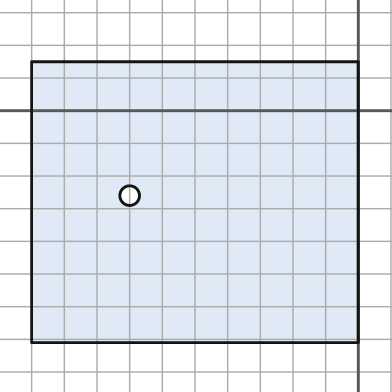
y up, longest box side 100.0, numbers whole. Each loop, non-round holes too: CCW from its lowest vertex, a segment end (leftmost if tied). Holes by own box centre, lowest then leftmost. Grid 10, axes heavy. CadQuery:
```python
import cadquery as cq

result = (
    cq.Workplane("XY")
    .moveTo(-100.0, -71.0)
    .lineTo(0.0, -71.0)
    .lineTo(0.0, 15.0)
    .lineTo(-100.0, 15.0)
    .close()
    .moveTo(-70.0, -26.0)
    .circle(3.0)
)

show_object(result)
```